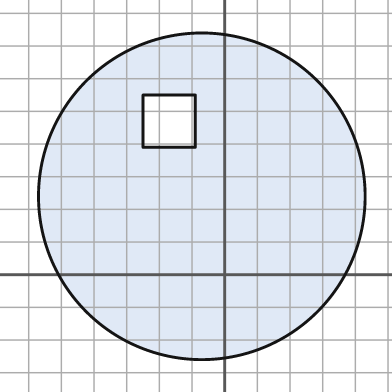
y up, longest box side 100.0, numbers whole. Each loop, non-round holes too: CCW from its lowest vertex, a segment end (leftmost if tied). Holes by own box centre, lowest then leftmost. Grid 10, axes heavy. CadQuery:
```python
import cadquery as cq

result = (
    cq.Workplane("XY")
    .moveTo(-7.0, 24.0)
    .circle(50.0)
    .moveTo(-25.0, 39.0)
    .lineTo(-9.0, 39.0)
    .lineTo(-9.0, 55.0)
    .lineTo(-25.0, 55.0)
    .close()
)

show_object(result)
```